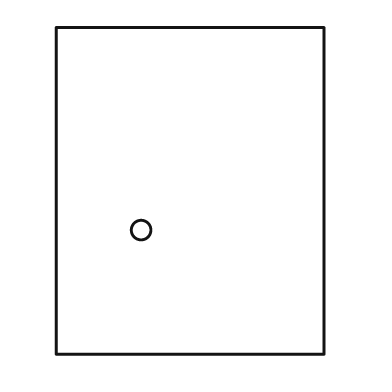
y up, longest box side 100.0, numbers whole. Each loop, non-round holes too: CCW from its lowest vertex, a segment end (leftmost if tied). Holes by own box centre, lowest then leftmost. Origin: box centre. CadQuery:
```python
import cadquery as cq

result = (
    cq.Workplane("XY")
    .moveTo(-41.0, -50.0)
    .lineTo(41.0, -50.0)
    .lineTo(41.0, 50.0)
    .lineTo(-41.0, 50.0)
    .close()
    .moveTo(-15.0, -12.0)
    .circle(3.0)
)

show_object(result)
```